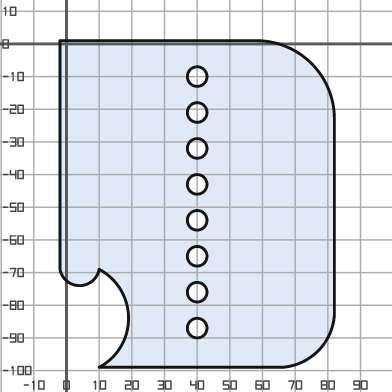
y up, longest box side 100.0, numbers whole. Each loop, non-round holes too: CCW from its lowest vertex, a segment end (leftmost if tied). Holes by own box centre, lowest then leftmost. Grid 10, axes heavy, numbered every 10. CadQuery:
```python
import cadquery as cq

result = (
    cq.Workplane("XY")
    .moveTo(10.0, -99.0)
    .lineTo(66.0, -99.0)
    .threePointArc((77.0, -94.0), (82.0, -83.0))
    .lineTo(82.0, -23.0)
    .threePointArc((75.0, -6.0), (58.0, 1.0))
    .lineTo(-2.0, 1.0)
    .lineTo(-2.0, -69.0)
    .threePointArc((4.0, -74.0), (10.0, -69.0))
    .threePointArc((19.0, -84.0), (10.0, -99.0))
    .close()
    .moveTo(40.0, -87.0)
    .circle(3.0)
    .moveTo(40.0, -76.0)
    .circle(3.0)
    .moveTo(40.0, -65.0)
    .circle(3.0)
    .moveTo(40.0, -54.0)
    .circle(3.0)
    .moveTo(40.0, -43.0)
    .circle(3.0)
    .moveTo(40.0, -32.0)
    .circle(3.0)
    .moveTo(40.0, -21.0)
    .circle(3.0)
    .moveTo(40.0, -10.0)
    .circle(3.0)
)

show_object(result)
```